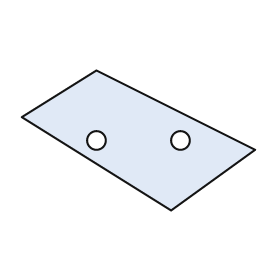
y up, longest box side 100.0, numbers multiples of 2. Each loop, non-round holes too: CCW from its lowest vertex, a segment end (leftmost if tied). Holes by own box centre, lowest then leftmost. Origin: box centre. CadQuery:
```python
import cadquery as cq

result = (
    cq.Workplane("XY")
    .moveTo(14.0, -30.0)
    .lineTo(50.0, -4.0)
    .lineTo(-18.0, 30.0)
    .lineTo(-50.0, 10.0)
    .close()
    .moveTo(-18.0, 0.0)
    .circle(4.0)
    .moveTo(18.0, 0.0)
    .circle(4.0)
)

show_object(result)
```